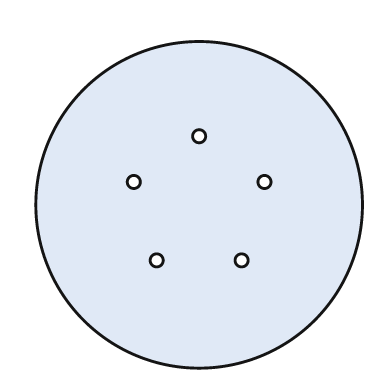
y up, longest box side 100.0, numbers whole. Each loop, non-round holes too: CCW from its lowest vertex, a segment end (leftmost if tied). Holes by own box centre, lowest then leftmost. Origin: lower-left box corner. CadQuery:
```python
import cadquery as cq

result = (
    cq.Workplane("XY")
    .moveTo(50.0, 50.0)
    .circle(50.0)
    .moveTo(37.0, 33.0)
    .circle(2.0)
    .moveTo(63.0, 33.0)
    .circle(2.0)
    .moveTo(30.0, 57.0)
    .circle(2.0)
    .moveTo(70.0, 57.0)
    .circle(2.0)
    .moveTo(50.0, 71.0)
    .circle(2.0)
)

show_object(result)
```